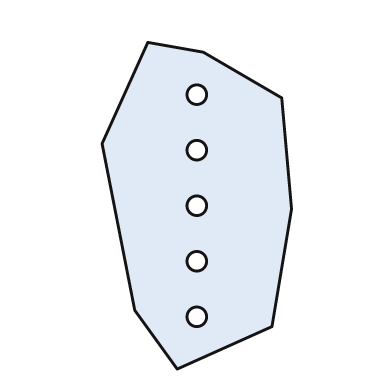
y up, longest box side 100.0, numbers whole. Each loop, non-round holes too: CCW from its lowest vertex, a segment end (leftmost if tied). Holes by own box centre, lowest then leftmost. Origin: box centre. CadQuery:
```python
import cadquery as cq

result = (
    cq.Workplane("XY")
    .moveTo(-6.0, -50.0)
    .lineTo(23.0, -37.0)
    .lineTo(29.0, -1.0)
    .lineTo(26.0, 33.0)
    .lineTo(2.0, 47.0)
    .lineTo(-15.0, 50.0)
    .lineTo(-29.0, 19.0)
    .lineTo(-19.0, -32.0)
    .close()
    .moveTo(0.0, -34.0)
    .circle(3.0)
    .moveTo(0.0, -17.0)
    .circle(3.0)
    .moveTo(0.0, 0.0)
    .circle(3.0)
    .moveTo(0.0, 17.0)
    .circle(3.0)
    .moveTo(0.0, 34.0)
    .circle(3.0)
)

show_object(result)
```